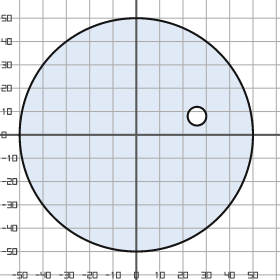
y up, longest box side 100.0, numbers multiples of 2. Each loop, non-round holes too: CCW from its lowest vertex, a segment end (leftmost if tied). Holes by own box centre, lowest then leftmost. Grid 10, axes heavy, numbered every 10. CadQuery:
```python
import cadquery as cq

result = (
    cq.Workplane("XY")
    .moveTo(0.0, 0.0)
    .circle(50.0)
    .moveTo(26.0, 8.0)
    .circle(4.0)
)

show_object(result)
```